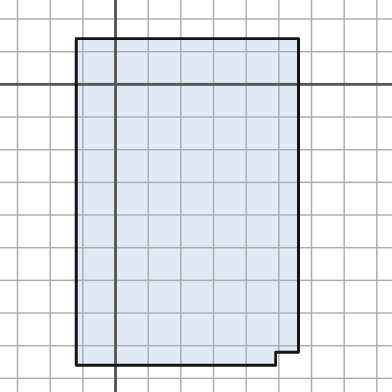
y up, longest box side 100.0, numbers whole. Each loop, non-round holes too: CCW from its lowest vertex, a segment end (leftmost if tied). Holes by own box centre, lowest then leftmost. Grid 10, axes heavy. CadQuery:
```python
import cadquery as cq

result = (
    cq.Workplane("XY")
    .moveTo(-12.0, -86.0)
    .lineTo(49.0, -86.0)
    .lineTo(49.0, -82.0)
    .lineTo(56.0, -82.0)
    .lineTo(56.0, 14.0)
    .lineTo(-12.0, 14.0)
    .close()
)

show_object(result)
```